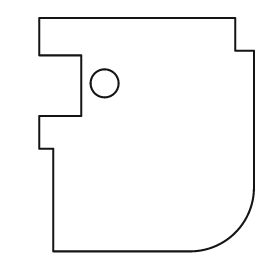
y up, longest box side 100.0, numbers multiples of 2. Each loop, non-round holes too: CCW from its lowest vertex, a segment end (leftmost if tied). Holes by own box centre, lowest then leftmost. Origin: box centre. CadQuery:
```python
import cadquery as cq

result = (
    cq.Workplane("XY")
    .moveTo(-40.0, -50.0)
    .lineTo(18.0, -50.0)
    .threePointArc((38.0, -42.0), (46.0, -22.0))
    .lineTo(46.0, 36.0)
    .lineTo(38.0, 36.0)
    .lineTo(38.0, 50.0)
    .lineTo(-46.0, 50.0)
    .lineTo(-46.0, 34.0)
    .lineTo(-28.0, 34.0)
    .lineTo(-28.0, 8.0)
    .lineTo(-46.0, 8.0)
    .lineTo(-46.0, -6.0)
    .lineTo(-40.0, -6.0)
    .close()
    .moveTo(-18.0, 22.0)
    .circle(6.0)
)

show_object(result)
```